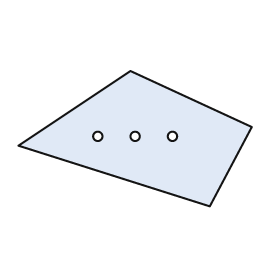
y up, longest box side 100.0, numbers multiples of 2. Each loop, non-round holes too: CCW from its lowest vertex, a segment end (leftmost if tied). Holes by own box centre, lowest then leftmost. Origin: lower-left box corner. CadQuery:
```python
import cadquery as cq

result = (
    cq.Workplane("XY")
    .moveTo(82.0, 0.0)
    .lineTo(100.0, 34.0)
    .lineTo(48.0, 58.0)
    .lineTo(0.0, 26.0)
    .close()
    .moveTo(34.0, 30.0)
    .circle(2.0)
    .moveTo(50.0, 30.0)
    .circle(2.0)
    .moveTo(66.0, 30.0)
    .circle(2.0)
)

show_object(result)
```